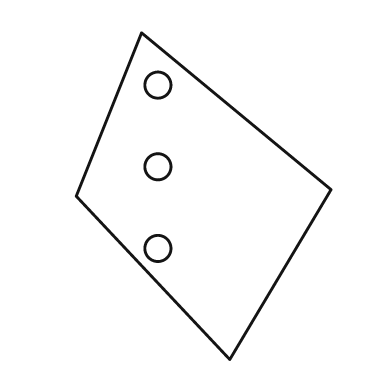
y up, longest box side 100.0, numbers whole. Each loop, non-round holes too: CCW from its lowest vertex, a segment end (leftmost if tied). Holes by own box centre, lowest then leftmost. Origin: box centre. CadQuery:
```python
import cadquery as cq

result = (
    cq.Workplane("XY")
    .moveTo(8.0, -50.0)
    .lineTo(39.0, 2.0)
    .lineTo(-19.0, 50.0)
    .lineTo(-39.0, 0.0)
    .close()
    .moveTo(-14.0, -16.0)
    .circle(4.0)
    .moveTo(-14.0, 9.0)
    .circle(4.0)
    .moveTo(-14.0, 34.0)
    .circle(4.0)
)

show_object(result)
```